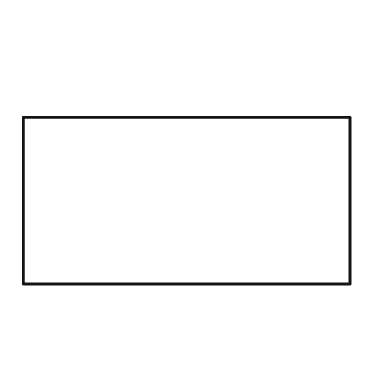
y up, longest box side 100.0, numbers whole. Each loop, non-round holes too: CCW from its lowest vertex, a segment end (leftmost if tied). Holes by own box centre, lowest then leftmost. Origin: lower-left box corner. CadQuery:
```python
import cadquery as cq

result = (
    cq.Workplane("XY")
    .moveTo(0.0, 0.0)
    .lineTo(100.0, 0.0)
    .lineTo(100.0, 51.0)
    .lineTo(0.0, 51.0)
    .close()
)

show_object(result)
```